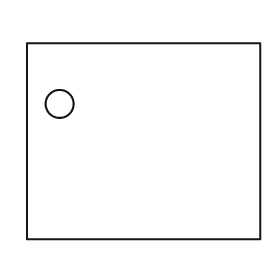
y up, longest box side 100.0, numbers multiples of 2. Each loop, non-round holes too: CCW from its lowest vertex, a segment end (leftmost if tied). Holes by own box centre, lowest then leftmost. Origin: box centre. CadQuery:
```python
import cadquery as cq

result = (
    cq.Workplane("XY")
    .moveTo(-50.0, -42.0)
    .lineTo(50.0, -42.0)
    .lineTo(50.0, 42.0)
    .lineTo(-50.0, 42.0)
    .close()
    .moveTo(-36.0, 16.0)
    .circle(6.0)
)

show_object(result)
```